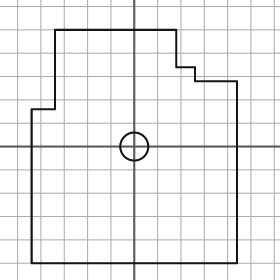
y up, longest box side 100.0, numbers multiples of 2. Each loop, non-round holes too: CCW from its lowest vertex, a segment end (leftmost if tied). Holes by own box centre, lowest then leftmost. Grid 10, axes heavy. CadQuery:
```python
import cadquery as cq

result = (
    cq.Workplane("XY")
    .moveTo(-44.0, -50.0)
    .lineTo(44.0, -50.0)
    .lineTo(44.0, 28.0)
    .lineTo(26.0, 28.0)
    .lineTo(26.0, 34.0)
    .lineTo(18.0, 34.0)
    .lineTo(18.0, 50.0)
    .lineTo(-34.0, 50.0)
    .lineTo(-34.0, 16.0)
    .lineTo(-44.0, 16.0)
    .close()
    .moveTo(0.0, 0.0)
    .circle(6.0)
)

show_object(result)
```